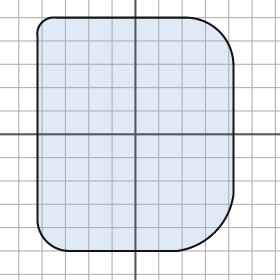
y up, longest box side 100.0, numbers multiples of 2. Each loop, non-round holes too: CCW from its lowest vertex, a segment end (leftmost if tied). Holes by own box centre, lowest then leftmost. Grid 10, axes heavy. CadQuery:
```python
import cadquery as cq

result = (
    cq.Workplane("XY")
    .moveTo(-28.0, -50.0)
    .lineTo(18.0, -50.0)
    .threePointArc((34.0, -42.0), (42.0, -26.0))
    .lineTo(42.0, 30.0)
    .threePointArc((36.0, 44.0), (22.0, 50.0))
    .lineTo(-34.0, 50.0)
    .threePointArc((-40.0, 48.0), (-42.0, 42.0))
    .lineTo(-42.0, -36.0)
    .threePointArc((-38.0, -46.0), (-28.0, -50.0))
    .close()
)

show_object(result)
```